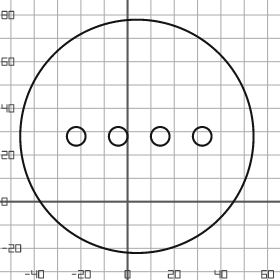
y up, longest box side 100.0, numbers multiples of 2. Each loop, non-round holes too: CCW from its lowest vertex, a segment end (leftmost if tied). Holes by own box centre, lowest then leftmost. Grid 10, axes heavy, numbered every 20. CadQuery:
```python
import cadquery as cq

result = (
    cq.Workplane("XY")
    .moveTo(4.0, 28.0)
    .circle(50.0)
    .moveTo(-22.0, 28.0)
    .circle(4.0)
    .moveTo(-4.0, 28.0)
    .circle(4.0)
    .moveTo(14.0, 28.0)
    .circle(4.0)
    .moveTo(32.0, 28.0)
    .circle(4.0)
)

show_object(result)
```